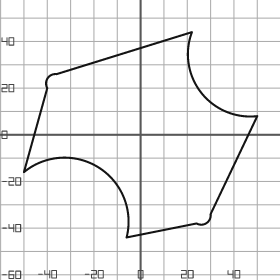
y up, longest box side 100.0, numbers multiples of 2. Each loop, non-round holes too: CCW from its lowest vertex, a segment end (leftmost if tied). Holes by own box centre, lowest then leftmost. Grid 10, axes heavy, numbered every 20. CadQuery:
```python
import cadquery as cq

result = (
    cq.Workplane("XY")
    .moveTo(-6.0, -44.0)
    .lineTo(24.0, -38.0)
    .threePointArc((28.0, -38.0), (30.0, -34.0))
    .lineTo(50.0, 8.0)
    .threePointArc((26.0, 18.0), (22.0, 44.0))
    .lineTo(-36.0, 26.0)
    .threePointArc((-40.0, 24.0), (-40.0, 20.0))
    .lineTo(-50.0, -16.0)
    .threePointArc((-18.0, -14.0), (-6.0, -44.0))
    .close()
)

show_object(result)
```